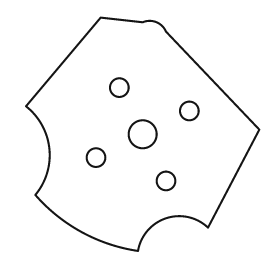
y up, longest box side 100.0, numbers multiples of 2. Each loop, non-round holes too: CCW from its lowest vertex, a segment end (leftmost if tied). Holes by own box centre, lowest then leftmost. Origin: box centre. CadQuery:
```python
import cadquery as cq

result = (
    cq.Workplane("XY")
    .moveTo(-2.0, -50.0)
    .threePointArc((10.0, -36.0), (28.0, -40.0))
    .lineTo(50.0, 2.0)
    .lineTo(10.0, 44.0)
    .threePointArc((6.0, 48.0), (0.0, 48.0))
    .lineTo(-18.0, 50.0)
    .lineTo(-50.0, 12.0)
    .threePointArc((-40.0, -6.0), (-46.0, -26.0))
    .threePointArc((-26.0, -42.0), (-2.0, -50.0))
    .close()
    .moveTo(10.0, -20.0)
    .circle(4.0)
    .moveTo(-20.0, -10.0)
    .circle(4.0)
    .moveTo(0.0, 0.0)
    .circle(6.0)
    .moveTo(20.0, 10.0)
    .circle(4.0)
    .moveTo(-10.0, 20.0)
    .circle(4.0)
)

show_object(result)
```